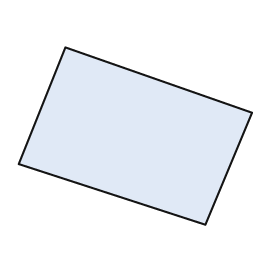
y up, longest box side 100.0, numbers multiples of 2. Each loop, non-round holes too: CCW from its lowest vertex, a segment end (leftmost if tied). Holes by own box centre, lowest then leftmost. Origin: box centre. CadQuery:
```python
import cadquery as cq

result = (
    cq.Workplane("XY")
    .moveTo(30.0, -38.0)
    .lineTo(50.0, 10.0)
    .lineTo(-30.0, 38.0)
    .lineTo(-50.0, -12.0)
    .close()
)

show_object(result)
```